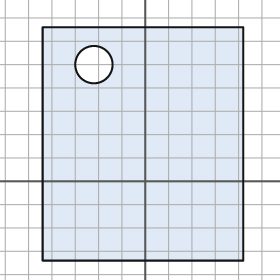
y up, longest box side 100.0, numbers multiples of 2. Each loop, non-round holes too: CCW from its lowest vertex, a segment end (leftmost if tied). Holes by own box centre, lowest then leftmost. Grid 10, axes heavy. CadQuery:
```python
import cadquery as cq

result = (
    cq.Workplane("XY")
    .moveTo(-44.0, -34.0)
    .lineTo(42.0, -34.0)
    .lineTo(42.0, 66.0)
    .lineTo(-44.0, 66.0)
    .close()
    .moveTo(-22.0, 50.0)
    .circle(8.0)
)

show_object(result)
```